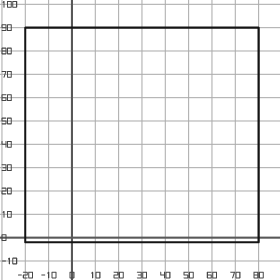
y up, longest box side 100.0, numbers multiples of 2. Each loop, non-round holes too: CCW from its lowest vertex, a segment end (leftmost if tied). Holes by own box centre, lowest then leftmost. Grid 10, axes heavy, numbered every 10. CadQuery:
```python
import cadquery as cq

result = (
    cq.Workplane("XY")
    .moveTo(-20.0, -2.0)
    .lineTo(80.0, -2.0)
    .lineTo(80.0, 90.0)
    .lineTo(-20.0, 90.0)
    .close()
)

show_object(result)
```